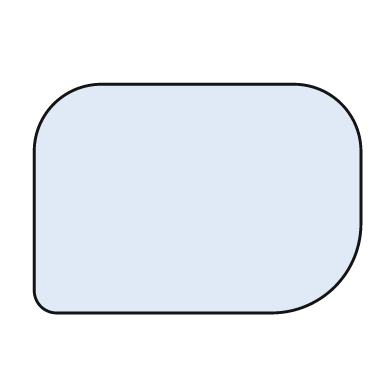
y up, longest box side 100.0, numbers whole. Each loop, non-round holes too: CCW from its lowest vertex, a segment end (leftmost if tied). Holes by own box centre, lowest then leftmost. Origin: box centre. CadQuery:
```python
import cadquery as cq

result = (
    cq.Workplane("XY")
    .moveTo(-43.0, -35.0)
    .lineTo(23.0, -35.0)
    .threePointArc((42.0, -27.0), (50.0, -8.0))
    .lineTo(50.0, 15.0)
    .threePointArc((44.0, 29.0), (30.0, 35.0))
    .lineTo(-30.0, 35.0)
    .threePointArc((-44.0, 29.0), (-50.0, 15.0))
    .lineTo(-50.0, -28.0)
    .threePointArc((-48.0, -33.0), (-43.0, -35.0))
    .close()
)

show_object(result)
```